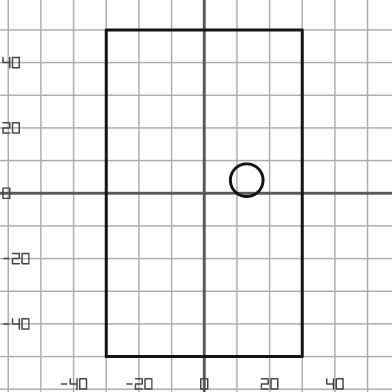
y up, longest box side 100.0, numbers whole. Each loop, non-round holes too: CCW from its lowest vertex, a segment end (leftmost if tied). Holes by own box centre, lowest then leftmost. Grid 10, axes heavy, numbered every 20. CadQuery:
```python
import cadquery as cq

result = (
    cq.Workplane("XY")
    .moveTo(-30.0, -50.0)
    .lineTo(30.0, -50.0)
    .lineTo(30.0, 50.0)
    .lineTo(-30.0, 50.0)
    .close()
    .moveTo(13.0, 4.0)
    .circle(5.0)
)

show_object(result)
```